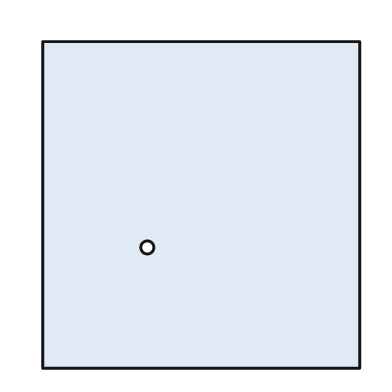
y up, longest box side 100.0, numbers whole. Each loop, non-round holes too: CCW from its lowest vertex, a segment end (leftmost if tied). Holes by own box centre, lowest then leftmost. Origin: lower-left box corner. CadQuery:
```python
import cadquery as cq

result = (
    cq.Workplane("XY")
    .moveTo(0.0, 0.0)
    .lineTo(97.0, 0.0)
    .lineTo(97.0, 100.0)
    .lineTo(0.0, 100.0)
    .close()
    .moveTo(32.0, 37.0)
    .circle(2.0)
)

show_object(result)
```